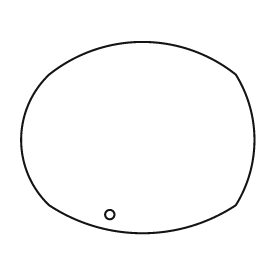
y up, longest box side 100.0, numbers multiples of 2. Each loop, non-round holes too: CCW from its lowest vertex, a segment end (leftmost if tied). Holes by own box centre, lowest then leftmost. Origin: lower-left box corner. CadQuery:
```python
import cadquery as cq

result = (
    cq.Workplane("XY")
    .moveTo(12.0, 12.0)
    .threePointArc((52.0, 0.0), (92.0, 12.0))
    .threePointArc((100.0, 40.0), (92.0, 68.0))
    .threePointArc((52.0, 82.0), (12.0, 68.0))
    .threePointArc((0.0, 40.0), (12.0, 12.0))
    .close()
    .moveTo(38.0, 8.0)
    .circle(2.0)
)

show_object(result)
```